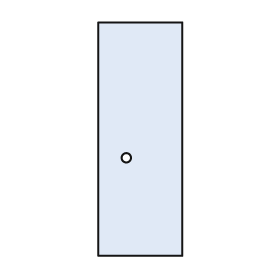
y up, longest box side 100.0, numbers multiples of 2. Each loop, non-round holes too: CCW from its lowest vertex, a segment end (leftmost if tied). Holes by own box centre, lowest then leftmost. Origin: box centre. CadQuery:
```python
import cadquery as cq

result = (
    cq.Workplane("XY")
    .moveTo(-18.0, -50.0)
    .lineTo(18.0, -50.0)
    .lineTo(18.0, 50.0)
    .lineTo(-18.0, 50.0)
    .close()
    .moveTo(-6.0, -8.0)
    .circle(2.0)
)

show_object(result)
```